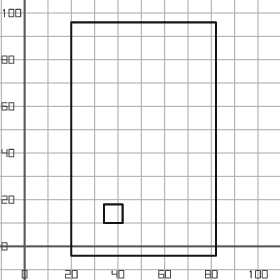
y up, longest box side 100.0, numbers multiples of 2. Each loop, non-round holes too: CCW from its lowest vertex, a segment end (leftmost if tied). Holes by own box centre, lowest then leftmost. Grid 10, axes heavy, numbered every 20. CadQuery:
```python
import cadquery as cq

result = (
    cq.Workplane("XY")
    .moveTo(20.0, -4.0)
    .lineTo(82.0, -4.0)
    .lineTo(82.0, 96.0)
    .lineTo(20.0, 96.0)
    .close()
    .moveTo(34.0, 10.0)
    .lineTo(42.0, 10.0)
    .lineTo(42.0, 18.0)
    .lineTo(34.0, 18.0)
    .close()
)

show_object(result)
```